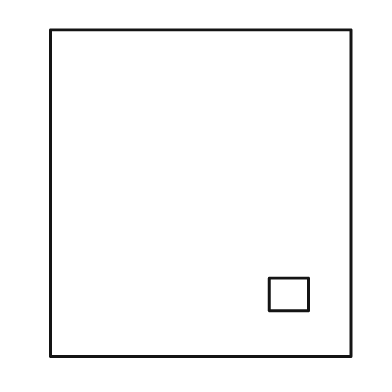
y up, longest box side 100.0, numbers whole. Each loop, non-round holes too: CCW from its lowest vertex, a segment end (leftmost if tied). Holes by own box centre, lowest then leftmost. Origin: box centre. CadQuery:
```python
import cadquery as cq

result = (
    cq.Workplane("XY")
    .moveTo(-46.0, -50.0)
    .lineTo(46.0, -50.0)
    .lineTo(46.0, 50.0)
    .lineTo(-46.0, 50.0)
    .close()
    .moveTo(21.0, -36.0)
    .lineTo(33.0, -36.0)
    .lineTo(33.0, -26.0)
    .lineTo(21.0, -26.0)
    .close()
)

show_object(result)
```